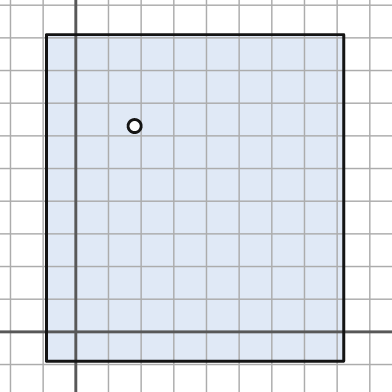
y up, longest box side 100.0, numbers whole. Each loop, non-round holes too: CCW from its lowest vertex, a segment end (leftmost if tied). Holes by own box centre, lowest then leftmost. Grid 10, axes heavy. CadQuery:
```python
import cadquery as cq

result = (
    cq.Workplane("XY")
    .moveTo(-9.0, -9.0)
    .lineTo(82.0, -9.0)
    .lineTo(82.0, 91.0)
    .lineTo(-9.0, 91.0)
    .close()
    .moveTo(18.0, 63.0)
    .circle(2.0)
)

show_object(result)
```